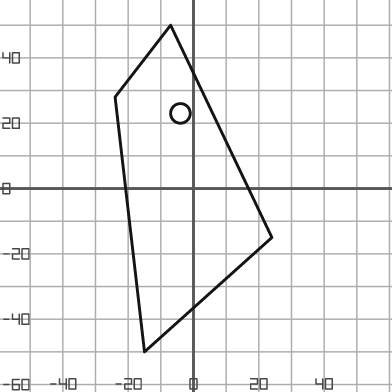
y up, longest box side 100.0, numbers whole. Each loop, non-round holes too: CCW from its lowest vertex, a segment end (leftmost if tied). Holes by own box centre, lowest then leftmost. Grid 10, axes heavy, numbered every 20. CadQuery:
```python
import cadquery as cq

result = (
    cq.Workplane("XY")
    .moveTo(-15.0, -50.0)
    .lineTo(24.0, -15.0)
    .lineTo(-7.0, 50.0)
    .lineTo(-24.0, 28.0)
    .close()
    .moveTo(-4.0, 23.0)
    .circle(3.0)
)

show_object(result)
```